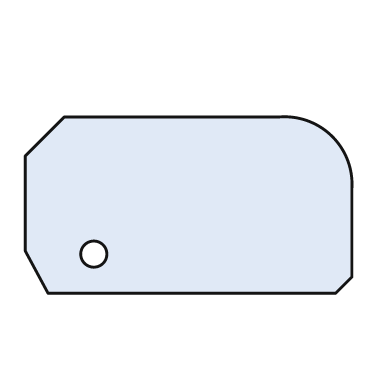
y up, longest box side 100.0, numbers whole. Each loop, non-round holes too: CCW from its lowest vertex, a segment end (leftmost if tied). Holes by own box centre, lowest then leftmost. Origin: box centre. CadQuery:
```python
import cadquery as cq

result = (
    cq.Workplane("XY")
    .moveTo(-43.0, -27.0)
    .lineTo(45.0, -27.0)
    .lineTo(50.0, -22.0)
    .lineTo(50.0, 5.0)
    .threePointArc((44.0, 21.0), (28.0, 27.0))
    .lineTo(-38.0, 27.0)
    .lineTo(-50.0, 15.0)
    .lineTo(-50.0, -14.0)
    .close()
    .moveTo(-29.0, -15.0)
    .circle(4.0)
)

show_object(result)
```